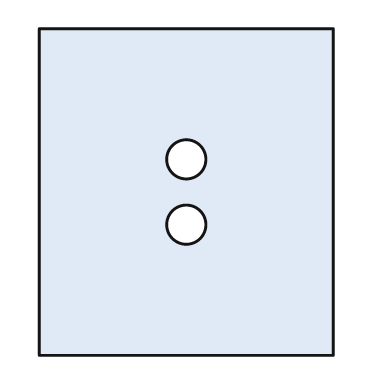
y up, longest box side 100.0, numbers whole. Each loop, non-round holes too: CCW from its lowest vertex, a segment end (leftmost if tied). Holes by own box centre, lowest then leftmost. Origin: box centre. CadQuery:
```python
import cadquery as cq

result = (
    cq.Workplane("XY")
    .moveTo(-45.0, -50.0)
    .lineTo(45.0, -50.0)
    .lineTo(45.0, 50.0)
    .lineTo(-45.0, 50.0)
    .close()
    .moveTo(0.0, -10.0)
    .circle(6.0)
    .moveTo(0.0, 10.0)
    .circle(6.0)
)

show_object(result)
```